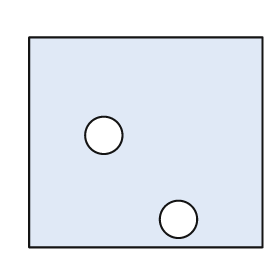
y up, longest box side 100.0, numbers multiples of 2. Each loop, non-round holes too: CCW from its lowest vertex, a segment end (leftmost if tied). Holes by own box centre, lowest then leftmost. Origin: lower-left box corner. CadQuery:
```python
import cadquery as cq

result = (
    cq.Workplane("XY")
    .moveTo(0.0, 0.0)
    .lineTo(100.0, 0.0)
    .lineTo(100.0, 90.0)
    .lineTo(0.0, 90.0)
    .close()
    .moveTo(64.0, 12.0)
    .circle(8.0)
    .moveTo(32.0, 48.0)
    .circle(8.0)
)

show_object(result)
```